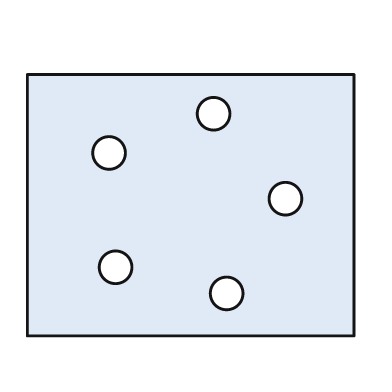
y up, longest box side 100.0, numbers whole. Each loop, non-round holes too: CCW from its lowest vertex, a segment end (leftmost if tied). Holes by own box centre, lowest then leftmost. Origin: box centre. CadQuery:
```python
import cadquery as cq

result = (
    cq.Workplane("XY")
    .moveTo(-50.0, -40.0)
    .lineTo(50.0, -40.0)
    .lineTo(50.0, 40.0)
    .lineTo(-50.0, 40.0)
    .close()
    .moveTo(11.0, -27.0)
    .circle(5.0)
    .moveTo(-23.0, -19.0)
    .circle(5.0)
    .moveTo(29.0, 2.0)
    .circle(5.0)
    .moveTo(-25.0, 16.0)
    .circle(5.0)
    .moveTo(7.0, 28.0)
    .circle(5.0)
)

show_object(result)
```